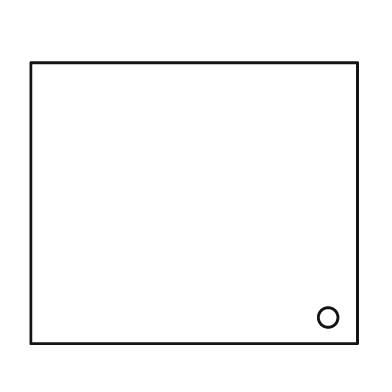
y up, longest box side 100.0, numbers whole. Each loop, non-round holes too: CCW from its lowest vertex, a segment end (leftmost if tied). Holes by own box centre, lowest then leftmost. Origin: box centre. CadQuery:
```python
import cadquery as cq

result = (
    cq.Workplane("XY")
    .moveTo(-50.0, -43.0)
    .lineTo(50.0, -43.0)
    .lineTo(50.0, 43.0)
    .lineTo(-50.0, 43.0)
    .close()
    .moveTo(41.0, -35.0)
    .circle(3.0)
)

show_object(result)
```